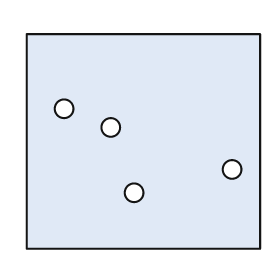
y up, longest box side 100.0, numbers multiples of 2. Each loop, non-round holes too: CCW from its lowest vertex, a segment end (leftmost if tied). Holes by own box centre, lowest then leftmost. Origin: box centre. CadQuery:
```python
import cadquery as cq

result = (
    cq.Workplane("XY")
    .moveTo(-50.0, -46.0)
    .lineTo(50.0, -46.0)
    .lineTo(50.0, 46.0)
    .lineTo(-50.0, 46.0)
    .close()
    .moveTo(-4.0, -22.0)
    .circle(4.0)
    .moveTo(38.0, -12.0)
    .circle(4.0)
    .moveTo(-14.0, 6.0)
    .circle(4.0)
    .moveTo(-34.0, 14.0)
    .circle(4.0)
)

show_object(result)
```